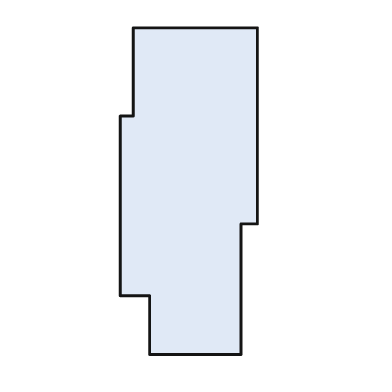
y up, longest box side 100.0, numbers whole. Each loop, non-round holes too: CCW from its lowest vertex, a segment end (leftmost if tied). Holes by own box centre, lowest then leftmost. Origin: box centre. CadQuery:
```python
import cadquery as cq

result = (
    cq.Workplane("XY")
    .moveTo(-12.0, -50.0)
    .lineTo(16.0, -50.0)
    .lineTo(16.0, -10.0)
    .lineTo(21.0, -10.0)
    .lineTo(21.0, 50.0)
    .lineTo(-17.0, 50.0)
    .lineTo(-17.0, 23.0)
    .lineTo(-21.0, 23.0)
    .lineTo(-21.0, -32.0)
    .lineTo(-12.0, -32.0)
    .close()
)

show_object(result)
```